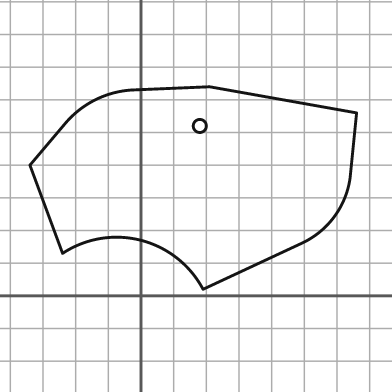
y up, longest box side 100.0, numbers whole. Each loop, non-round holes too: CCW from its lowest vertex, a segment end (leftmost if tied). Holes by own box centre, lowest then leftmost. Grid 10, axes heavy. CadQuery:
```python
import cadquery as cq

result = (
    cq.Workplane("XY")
    .moveTo(19.0, 2.0)
    .lineTo(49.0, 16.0)
    .threePointArc((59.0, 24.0), (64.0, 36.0))
    .lineTo(66.0, 56.0)
    .lineTo(21.0, 64.0)
    .lineTo(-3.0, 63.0)
    .threePointArc((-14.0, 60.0), (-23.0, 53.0))
    .lineTo(-34.0, 40.0)
    .lineTo(-24.0, 13.0)
    .threePointArc((0.0, 17.0), (19.0, 2.0))
    .close()
    .moveTo(18.0, 52.0)
    .circle(2.0)
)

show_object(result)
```